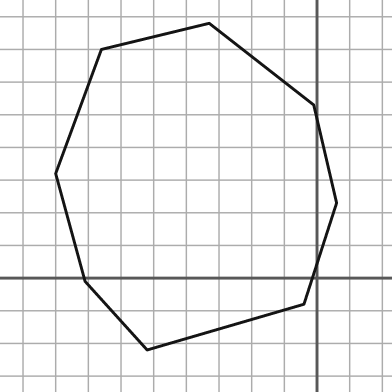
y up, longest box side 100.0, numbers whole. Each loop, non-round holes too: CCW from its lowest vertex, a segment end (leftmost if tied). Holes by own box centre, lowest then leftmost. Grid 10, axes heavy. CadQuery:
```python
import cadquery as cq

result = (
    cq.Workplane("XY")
    .moveTo(-52.0, -22.0)
    .lineTo(-4.0, -8.0)
    .lineTo(6.0, 23.0)
    .lineTo(-1.0, 53.0)
    .lineTo(-33.0, 78.0)
    .lineTo(-66.0, 70.0)
    .lineTo(-80.0, 32.0)
    .lineTo(-71.0, -1.0)
    .close()
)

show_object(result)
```